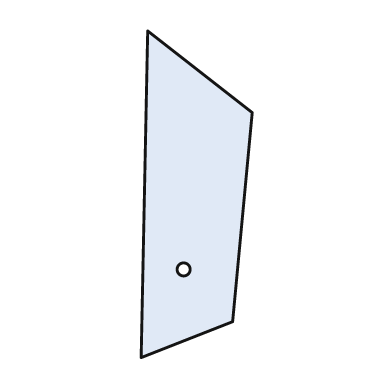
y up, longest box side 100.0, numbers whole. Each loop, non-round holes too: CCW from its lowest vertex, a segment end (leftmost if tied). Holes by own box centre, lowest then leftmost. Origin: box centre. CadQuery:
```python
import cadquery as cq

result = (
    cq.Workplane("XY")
    .moveTo(-17.0, -50.0)
    .lineTo(11.0, -39.0)
    .lineTo(17.0, 25.0)
    .lineTo(-15.0, 50.0)
    .close()
    .moveTo(-4.0, -23.0)
    .circle(2.0)
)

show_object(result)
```